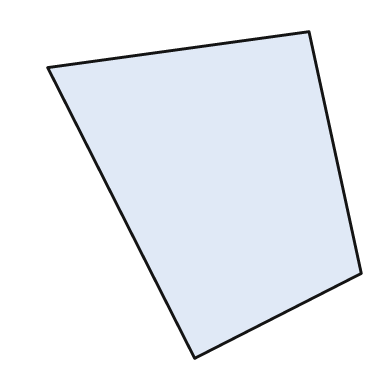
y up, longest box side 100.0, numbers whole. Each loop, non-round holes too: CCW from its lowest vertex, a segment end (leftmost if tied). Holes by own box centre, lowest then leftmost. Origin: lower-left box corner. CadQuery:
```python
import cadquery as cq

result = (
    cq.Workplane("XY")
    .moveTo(45.0, 0.0)
    .lineTo(96.0, 26.0)
    .lineTo(80.0, 100.0)
    .lineTo(0.0, 89.0)
    .close()
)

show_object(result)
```